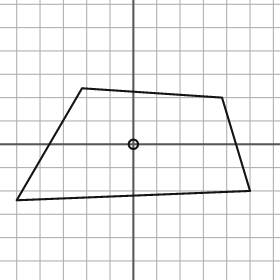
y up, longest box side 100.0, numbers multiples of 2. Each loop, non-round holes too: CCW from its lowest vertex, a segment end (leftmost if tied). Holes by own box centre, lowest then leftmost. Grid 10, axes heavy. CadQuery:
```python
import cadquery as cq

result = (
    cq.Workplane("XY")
    .moveTo(-50.0, -24.0)
    .lineTo(50.0, -20.0)
    .lineTo(38.0, 20.0)
    .lineTo(-22.0, 24.0)
    .close()
    .moveTo(0.0, 0.0)
    .circle(2.0)
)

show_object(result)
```